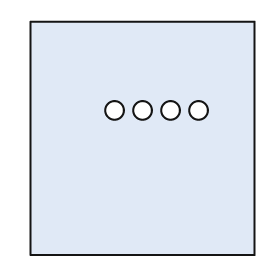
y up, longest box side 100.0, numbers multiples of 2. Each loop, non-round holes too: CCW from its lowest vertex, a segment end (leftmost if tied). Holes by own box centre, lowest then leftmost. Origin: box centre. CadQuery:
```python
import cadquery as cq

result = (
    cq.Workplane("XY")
    .moveTo(-48.0, -50.0)
    .lineTo(48.0, -50.0)
    .lineTo(48.0, 50.0)
    .lineTo(-48.0, 50.0)
    .close()
    .moveTo(-12.0, 12.0)
    .circle(4.0)
    .moveTo(0.0, 12.0)
    .circle(4.0)
    .moveTo(12.0, 12.0)
    .circle(4.0)
    .moveTo(24.0, 12.0)
    .circle(4.0)
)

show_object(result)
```